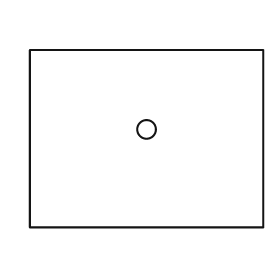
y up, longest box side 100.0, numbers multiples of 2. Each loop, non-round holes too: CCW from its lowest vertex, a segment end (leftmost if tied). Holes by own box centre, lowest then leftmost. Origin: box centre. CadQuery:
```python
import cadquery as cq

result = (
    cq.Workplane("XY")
    .moveTo(-50.0, -38.0)
    .lineTo(50.0, -38.0)
    .lineTo(50.0, 38.0)
    .lineTo(-50.0, 38.0)
    .close()
    .moveTo(0.0, 4.0)
    .circle(4.0)
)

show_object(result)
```